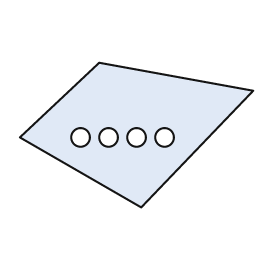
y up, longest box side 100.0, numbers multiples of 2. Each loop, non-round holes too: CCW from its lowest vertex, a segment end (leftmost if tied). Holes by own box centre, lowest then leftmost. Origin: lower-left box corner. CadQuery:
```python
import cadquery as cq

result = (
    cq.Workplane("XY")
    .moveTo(52.0, 0.0)
    .lineTo(100.0, 50.0)
    .lineTo(34.0, 62.0)
    .lineTo(0.0, 30.0)
    .close()
    .moveTo(26.0, 30.0)
    .circle(4.0)
    .moveTo(38.0, 30.0)
    .circle(4.0)
    .moveTo(50.0, 30.0)
    .circle(4.0)
    .moveTo(62.0, 30.0)
    .circle(4.0)
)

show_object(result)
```